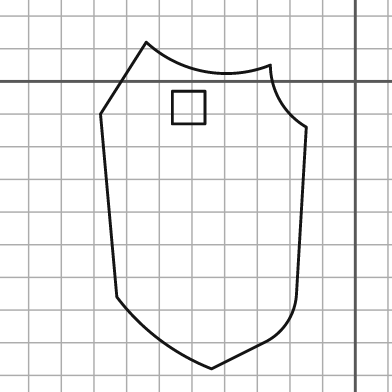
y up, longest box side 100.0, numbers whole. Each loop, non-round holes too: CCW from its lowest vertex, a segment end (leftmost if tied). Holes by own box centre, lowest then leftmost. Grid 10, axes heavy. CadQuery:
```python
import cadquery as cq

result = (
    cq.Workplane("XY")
    .moveTo(-44.0, -88.0)
    .lineTo(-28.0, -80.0)
    .threePointArc((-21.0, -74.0), (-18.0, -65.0))
    .lineTo(-15.0, -14.0)
    .threePointArc((-23.0, -6.0), (-26.0, 5.0))
    .threePointArc((-46.0, 3.0), (-64.0, 12.0))
    .lineTo(-78.0, -10.0)
    .lineTo(-73.0, -66.0)
    .threePointArc((-60.0, -79.0), (-44.0, -88.0))
    .close()
    .moveTo(-56.0, -13.0)
    .lineTo(-46.0, -13.0)
    .lineTo(-46.0, -3.0)
    .lineTo(-56.0, -3.0)
    .close()
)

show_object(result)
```